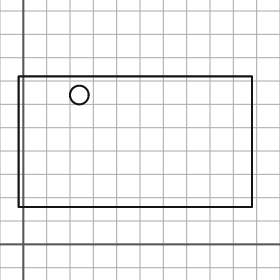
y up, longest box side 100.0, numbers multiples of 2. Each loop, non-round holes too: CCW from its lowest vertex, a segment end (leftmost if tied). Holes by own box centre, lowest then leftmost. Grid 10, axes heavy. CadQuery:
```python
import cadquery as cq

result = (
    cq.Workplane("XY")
    .moveTo(-2.0, 16.0)
    .lineTo(98.0, 16.0)
    .lineTo(98.0, 72.0)
    .lineTo(-2.0, 72.0)
    .close()
    .moveTo(24.0, 64.0)
    .circle(4.0)
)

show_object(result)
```